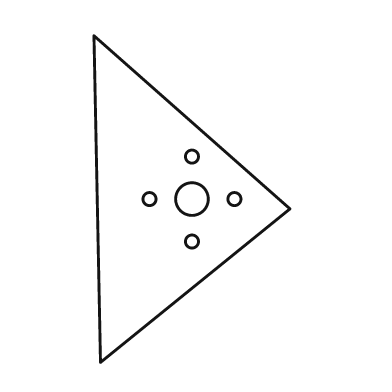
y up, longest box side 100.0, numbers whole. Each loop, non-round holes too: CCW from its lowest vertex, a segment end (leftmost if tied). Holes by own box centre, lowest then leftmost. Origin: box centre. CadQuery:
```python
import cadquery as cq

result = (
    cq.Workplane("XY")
    .moveTo(-28.0, -50.0)
    .lineTo(30.0, -3.0)
    .lineTo(-30.0, 50.0)
    .close()
    .moveTo(0.0, -13.0)
    .circle(2.0)
    .moveTo(-13.0, 0.0)
    .circle(2.0)
    .moveTo(0.0, 0.0)
    .circle(5.0)
    .moveTo(13.0, 0.0)
    .circle(2.0)
    .moveTo(0.0, 13.0)
    .circle(2.0)
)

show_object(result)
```